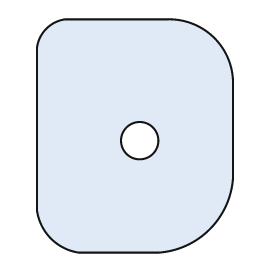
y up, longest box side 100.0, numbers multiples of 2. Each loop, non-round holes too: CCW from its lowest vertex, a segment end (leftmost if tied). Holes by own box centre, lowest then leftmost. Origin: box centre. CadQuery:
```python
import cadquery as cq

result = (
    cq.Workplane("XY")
    .moveTo(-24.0, -50.0)
    .lineTo(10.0, -50.0)
    .threePointArc((32.0, -40.0), (42.0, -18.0))
    .lineTo(42.0, 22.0)
    .threePointArc((34.0, 42.0), (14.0, 50.0))
    .lineTo(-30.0, 50.0)
    .threePointArc((-38.0, 46.0), (-42.0, 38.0))
    .lineTo(-42.0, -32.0)
    .threePointArc((-36.0, -44.0), (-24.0, -50.0))
    .close()
    .moveTo(2.0, -2.0)
    .circle(8.0)
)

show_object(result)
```